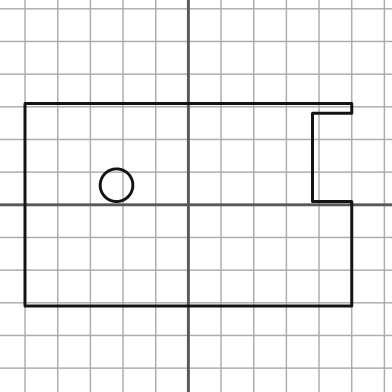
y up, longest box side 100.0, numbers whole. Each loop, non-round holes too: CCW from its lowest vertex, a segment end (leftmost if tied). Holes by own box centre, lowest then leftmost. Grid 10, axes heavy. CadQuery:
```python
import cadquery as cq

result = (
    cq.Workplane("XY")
    .moveTo(-50.0, -31.0)
    .lineTo(50.0, -31.0)
    .lineTo(50.0, 1.0)
    .lineTo(38.0, 1.0)
    .lineTo(38.0, 28.0)
    .lineTo(50.0, 28.0)
    .lineTo(50.0, 31.0)
    .lineTo(-50.0, 31.0)
    .close()
    .moveTo(-22.0, 6.0)
    .circle(5.0)
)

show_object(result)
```